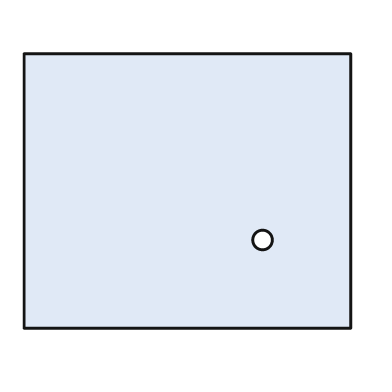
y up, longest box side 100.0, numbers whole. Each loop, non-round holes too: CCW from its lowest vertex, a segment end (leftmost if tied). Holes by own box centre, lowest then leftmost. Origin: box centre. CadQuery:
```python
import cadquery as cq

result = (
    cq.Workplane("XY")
    .moveTo(-50.0, -42.0)
    .lineTo(50.0, -42.0)
    .lineTo(50.0, 42.0)
    .lineTo(-50.0, 42.0)
    .close()
    .moveTo(23.0, -15.0)
    .circle(3.0)
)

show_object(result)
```